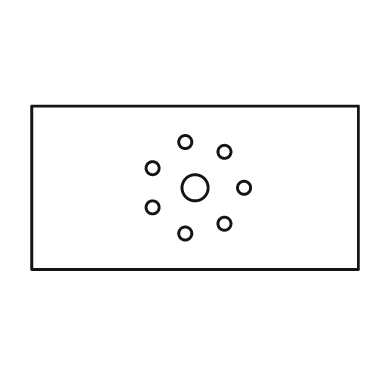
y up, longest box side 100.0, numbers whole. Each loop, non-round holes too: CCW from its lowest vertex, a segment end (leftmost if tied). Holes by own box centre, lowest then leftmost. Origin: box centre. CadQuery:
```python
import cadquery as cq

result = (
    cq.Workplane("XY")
    .moveTo(-50.0, -25.0)
    .lineTo(50.0, -25.0)
    .lineTo(50.0, 25.0)
    .lineTo(-50.0, 25.0)
    .close()
    .moveTo(-3.0, -14.0)
    .circle(2.0)
    .moveTo(9.0, -11.0)
    .circle(2.0)
    .moveTo(-13.0, -6.0)
    .circle(2.0)
    .moveTo(0.0, 0.0)
    .circle(4.0)
    .moveTo(15.0, 0.0)
    .circle(2.0)
    .moveTo(-13.0, 6.0)
    .circle(2.0)
    .moveTo(9.0, 11.0)
    .circle(2.0)
    .moveTo(-3.0, 14.0)
    .circle(2.0)
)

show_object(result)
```